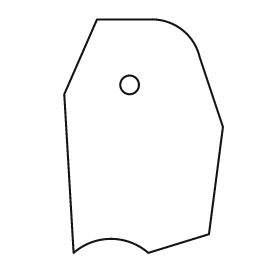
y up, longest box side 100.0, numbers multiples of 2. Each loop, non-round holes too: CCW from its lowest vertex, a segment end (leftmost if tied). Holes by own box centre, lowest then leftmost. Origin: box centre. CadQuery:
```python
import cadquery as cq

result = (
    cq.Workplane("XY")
    .moveTo(-30.0, -50.0)
    .threePointArc((-14.0, -44.0), (2.0, -50.0))
    .lineTo(28.0, -42.0)
    .lineTo(34.0, 4.0)
    .lineTo(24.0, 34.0)
    .threePointArc((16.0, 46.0), (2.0, 50.0))
    .lineTo(-20.0, 50.0)
    .lineTo(-34.0, 18.0)
    .close()
    .moveTo(-6.0, 22.0)
    .circle(4.0)
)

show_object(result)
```